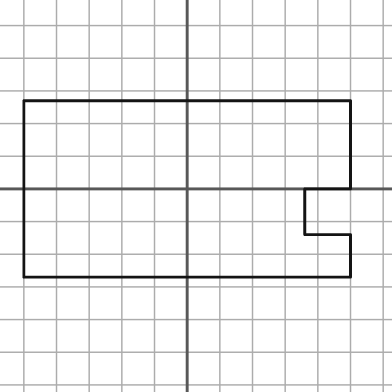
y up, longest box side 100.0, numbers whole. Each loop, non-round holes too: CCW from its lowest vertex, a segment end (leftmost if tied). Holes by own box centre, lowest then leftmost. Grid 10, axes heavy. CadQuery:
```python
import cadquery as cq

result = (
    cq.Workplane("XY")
    .moveTo(-50.0, -27.0)
    .lineTo(50.0, -27.0)
    .lineTo(50.0, -14.0)
    .lineTo(36.0, -14.0)
    .lineTo(36.0, 0.0)
    .lineTo(50.0, 0.0)
    .lineTo(50.0, 27.0)
    .lineTo(-50.0, 27.0)
    .close()
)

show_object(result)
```